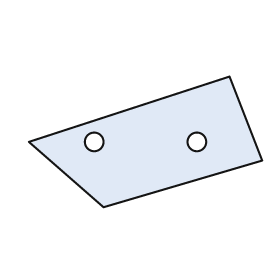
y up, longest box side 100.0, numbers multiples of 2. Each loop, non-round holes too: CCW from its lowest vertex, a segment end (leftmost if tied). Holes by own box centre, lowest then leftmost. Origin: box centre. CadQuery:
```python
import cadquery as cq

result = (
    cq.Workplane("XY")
    .moveTo(-18.0, -28.0)
    .lineTo(50.0, -8.0)
    .lineTo(36.0, 28.0)
    .lineTo(-50.0, 0.0)
    .close()
    .moveTo(-22.0, 0.0)
    .circle(4.0)
    .moveTo(22.0, 0.0)
    .circle(4.0)
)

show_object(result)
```